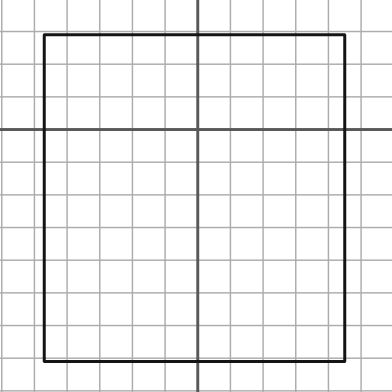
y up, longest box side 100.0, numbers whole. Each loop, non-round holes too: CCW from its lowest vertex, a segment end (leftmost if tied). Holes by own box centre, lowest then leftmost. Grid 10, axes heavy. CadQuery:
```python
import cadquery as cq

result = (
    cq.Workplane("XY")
    .moveTo(-47.0, -71.0)
    .lineTo(45.0, -71.0)
    .lineTo(45.0, 29.0)
    .lineTo(-47.0, 29.0)
    .close()
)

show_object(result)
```